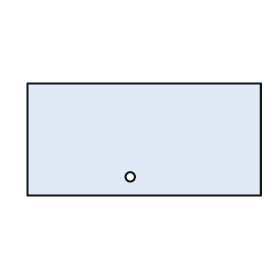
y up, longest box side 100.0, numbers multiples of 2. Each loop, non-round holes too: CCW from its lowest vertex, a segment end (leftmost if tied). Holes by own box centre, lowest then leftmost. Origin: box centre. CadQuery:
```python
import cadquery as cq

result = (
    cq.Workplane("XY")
    .moveTo(-50.0, -24.0)
    .lineTo(50.0, -24.0)
    .lineTo(50.0, 24.0)
    .lineTo(-50.0, 24.0)
    .close()
    .moveTo(-6.0, -16.0)
    .circle(2.0)
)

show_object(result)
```